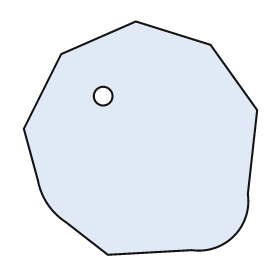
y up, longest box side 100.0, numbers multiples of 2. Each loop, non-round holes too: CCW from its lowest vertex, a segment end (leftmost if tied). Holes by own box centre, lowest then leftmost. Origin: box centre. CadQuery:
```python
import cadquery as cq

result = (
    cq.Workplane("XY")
    .moveTo(-14.0, -50.0)
    .lineTo(22.0, -48.0)
    .threePointArc((40.0, -42.0), (46.0, -24.0))
    .lineTo(50.0, 12.0)
    .lineTo(30.0, 40.0)
    .lineTo(-2.0, 50.0)
    .lineTo(-34.0, 36.0)
    .lineTo(-50.0, 4.0)
    .lineTo(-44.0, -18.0)
    .threePointArc((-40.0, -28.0), (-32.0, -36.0))
    .close()
    .moveTo(-16.0, 18.0)
    .circle(4.0)
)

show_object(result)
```